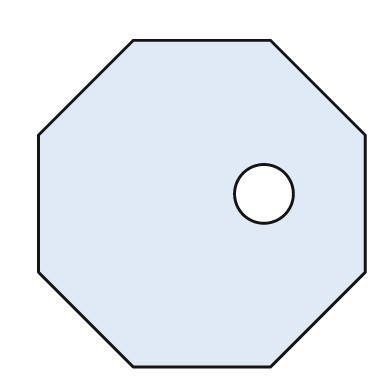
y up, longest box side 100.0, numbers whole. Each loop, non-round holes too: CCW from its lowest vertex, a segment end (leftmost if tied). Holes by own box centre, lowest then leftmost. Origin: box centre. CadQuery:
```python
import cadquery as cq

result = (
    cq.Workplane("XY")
    .moveTo(-21.0, -50.0)
    .lineTo(21.0, -50.0)
    .lineTo(50.0, -21.0)
    .lineTo(50.0, 21.0)
    .lineTo(21.0, 50.0)
    .lineTo(-21.0, 50.0)
    .lineTo(-50.0, 21.0)
    .lineTo(-50.0, -21.0)
    .close()
    .moveTo(19.0, 3.0)
    .circle(9.0)
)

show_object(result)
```